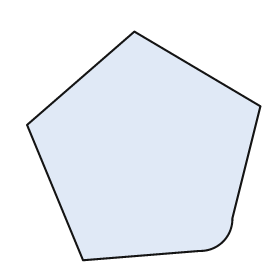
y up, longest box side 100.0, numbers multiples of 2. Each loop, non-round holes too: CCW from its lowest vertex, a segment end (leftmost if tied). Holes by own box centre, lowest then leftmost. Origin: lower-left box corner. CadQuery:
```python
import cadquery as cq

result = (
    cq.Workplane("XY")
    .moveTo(24.0, 0.0)
    .lineTo(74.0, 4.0)
    .threePointArc((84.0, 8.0), (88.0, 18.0))
    .lineTo(100.0, 66.0)
    .lineTo(46.0, 98.0)
    .lineTo(0.0, 58.0)
    .close()
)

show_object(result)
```